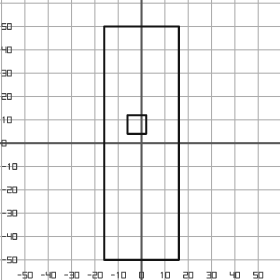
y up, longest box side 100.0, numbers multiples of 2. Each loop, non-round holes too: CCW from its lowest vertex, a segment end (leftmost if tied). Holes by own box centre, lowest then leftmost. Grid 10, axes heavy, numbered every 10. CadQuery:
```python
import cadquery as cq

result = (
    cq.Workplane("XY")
    .moveTo(-16.0, -50.0)
    .lineTo(16.0, -50.0)
    .lineTo(16.0, 50.0)
    .lineTo(-16.0, 50.0)
    .close()
    .moveTo(-6.0, 4.0)
    .lineTo(2.0, 4.0)
    .lineTo(2.0, 12.0)
    .lineTo(-6.0, 12.0)
    .close()
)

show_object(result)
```